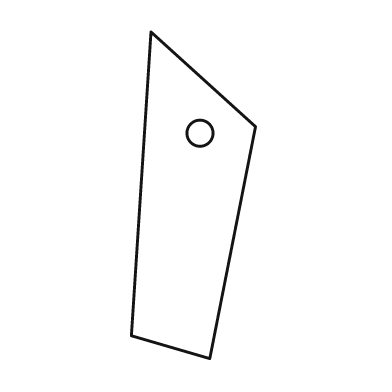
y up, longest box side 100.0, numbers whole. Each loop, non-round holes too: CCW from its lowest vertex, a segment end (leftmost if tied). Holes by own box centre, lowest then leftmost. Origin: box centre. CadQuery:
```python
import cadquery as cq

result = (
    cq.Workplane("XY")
    .moveTo(5.0, -50.0)
    .lineTo(19.0, 21.0)
    .lineTo(-13.0, 50.0)
    .lineTo(-19.0, -43.0)
    .close()
    .moveTo(2.0, 19.0)
    .circle(4.0)
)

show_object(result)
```